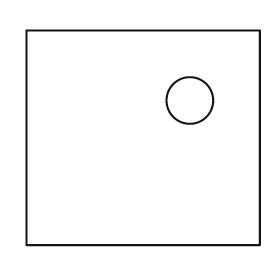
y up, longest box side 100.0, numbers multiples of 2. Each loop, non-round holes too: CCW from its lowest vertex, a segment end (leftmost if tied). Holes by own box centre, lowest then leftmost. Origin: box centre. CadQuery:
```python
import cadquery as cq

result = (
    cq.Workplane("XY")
    .moveTo(-50.0, -46.0)
    .lineTo(50.0, -46.0)
    .lineTo(50.0, 46.0)
    .lineTo(-50.0, 46.0)
    .close()
    .moveTo(20.0, 16.0)
    .circle(10.0)
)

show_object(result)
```